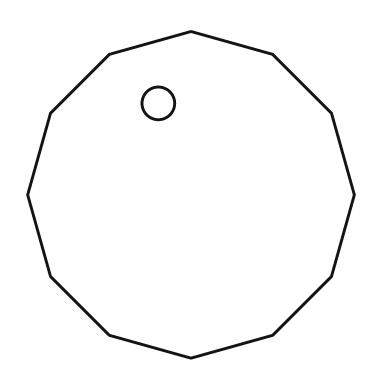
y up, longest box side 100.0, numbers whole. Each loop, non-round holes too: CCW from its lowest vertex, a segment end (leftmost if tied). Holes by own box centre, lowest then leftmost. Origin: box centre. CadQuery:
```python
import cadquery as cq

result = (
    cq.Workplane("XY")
    .moveTo(0.0, -50.0)
    .lineTo(25.0, -43.0)
    .lineTo(43.0, -25.0)
    .lineTo(50.0, 0.0)
    .lineTo(43.0, 25.0)
    .lineTo(25.0, 43.0)
    .lineTo(0.0, 50.0)
    .lineTo(-25.0, 43.0)
    .lineTo(-43.0, 25.0)
    .lineTo(-50.0, 0.0)
    .lineTo(-43.0, -25.0)
    .lineTo(-25.0, -43.0)
    .close()
    .moveTo(-10.0, 28.0)
    .circle(5.0)
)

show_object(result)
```